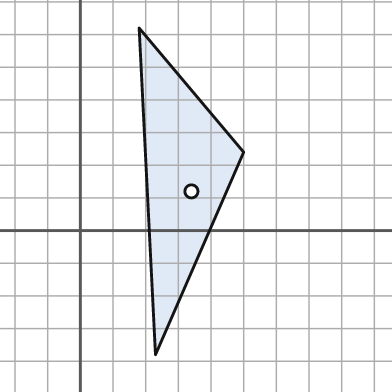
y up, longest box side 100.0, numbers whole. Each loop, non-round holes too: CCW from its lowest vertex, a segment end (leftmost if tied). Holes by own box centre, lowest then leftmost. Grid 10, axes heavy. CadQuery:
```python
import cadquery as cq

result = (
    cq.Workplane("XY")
    .moveTo(23.0, -38.0)
    .lineTo(50.0, 24.0)
    .lineTo(18.0, 62.0)
    .close()
    .moveTo(34.0, 12.0)
    .circle(2.0)
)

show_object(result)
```